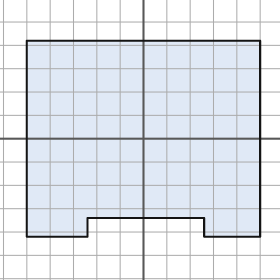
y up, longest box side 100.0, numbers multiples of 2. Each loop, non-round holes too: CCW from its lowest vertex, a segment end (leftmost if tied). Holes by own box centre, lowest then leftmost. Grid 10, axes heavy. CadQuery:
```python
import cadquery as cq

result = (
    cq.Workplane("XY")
    .moveTo(-50.0, -42.0)
    .lineTo(-24.0, -42.0)
    .lineTo(-24.0, -34.0)
    .lineTo(26.0, -34.0)
    .lineTo(26.0, -42.0)
    .lineTo(50.0, -42.0)
    .lineTo(50.0, 42.0)
    .lineTo(-50.0, 42.0)
    .close()
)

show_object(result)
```